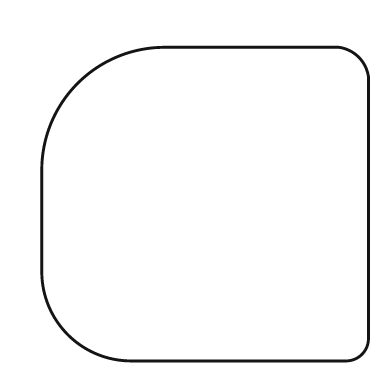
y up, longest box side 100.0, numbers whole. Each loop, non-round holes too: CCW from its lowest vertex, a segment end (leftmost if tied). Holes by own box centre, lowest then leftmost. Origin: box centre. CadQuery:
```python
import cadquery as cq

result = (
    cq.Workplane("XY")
    .moveTo(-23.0, -48.0)
    .lineTo(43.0, -48.0)
    .threePointArc((48.0, -46.0), (50.0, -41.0))
    .lineTo(50.0, 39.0)
    .threePointArc((47.0, 45.0), (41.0, 48.0))
    .lineTo(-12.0, 48.0)
    .threePointArc((-39.0, 37.0), (-50.0, 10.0))
    .lineTo(-50.0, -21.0)
    .threePointArc((-42.0, -40.0), (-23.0, -48.0))
    .close()
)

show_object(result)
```